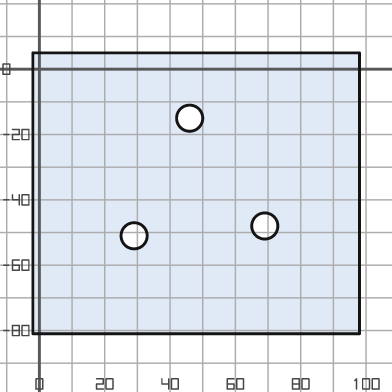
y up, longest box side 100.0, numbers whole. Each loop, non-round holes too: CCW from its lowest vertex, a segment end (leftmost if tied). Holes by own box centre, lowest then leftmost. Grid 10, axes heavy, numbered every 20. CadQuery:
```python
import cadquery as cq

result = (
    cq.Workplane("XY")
    .moveTo(-2.0, -81.0)
    .lineTo(98.0, -81.0)
    .lineTo(98.0, 5.0)
    .lineTo(-2.0, 5.0)
    .close()
    .moveTo(29.0, -51.0)
    .circle(4.0)
    .moveTo(69.0, -48.0)
    .circle(4.0)
    .moveTo(46.0, -15.0)
    .circle(4.0)
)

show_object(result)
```